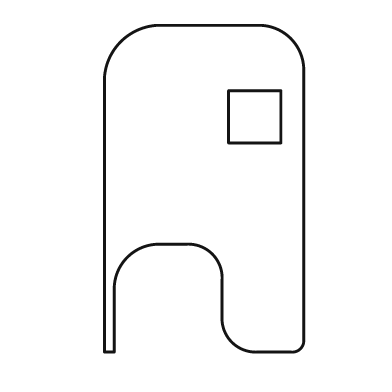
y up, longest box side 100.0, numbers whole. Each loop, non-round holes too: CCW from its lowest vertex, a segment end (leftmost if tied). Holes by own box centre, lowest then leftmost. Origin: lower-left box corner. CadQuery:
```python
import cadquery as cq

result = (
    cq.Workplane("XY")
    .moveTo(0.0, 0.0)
    .lineTo(3.0, 0.0)
    .lineTo(3.0, 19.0)
    .threePointArc((7.0, 29.0), (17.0, 33.0))
    .lineTo(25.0, 33.0)
    .threePointArc((33.0, 30.0), (36.0, 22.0))
    .lineTo(36.0, 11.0)
    .threePointArc((39.0, 3.0), (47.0, 0.0))
    .lineTo(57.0, 0.0)
    .threePointArc((60.0, 1.0), (61.0, 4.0))
    .lineTo(61.0, 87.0)
    .threePointArc((57.0, 96.0), (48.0, 100.0))
    .lineTo(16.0, 100.0)
    .threePointArc((5.0, 95.0), (0.0, 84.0))
    .close()
    .moveTo(38.0, 64.0)
    .lineTo(54.0, 64.0)
    .lineTo(54.0, 80.0)
    .lineTo(38.0, 80.0)
    .close()
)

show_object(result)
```